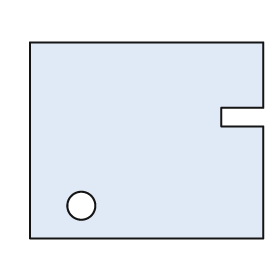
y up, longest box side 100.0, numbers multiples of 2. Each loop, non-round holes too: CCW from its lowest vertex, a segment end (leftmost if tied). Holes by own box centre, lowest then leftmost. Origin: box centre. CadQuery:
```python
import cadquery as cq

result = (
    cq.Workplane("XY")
    .moveTo(-50.0, -42.0)
    .lineTo(50.0, -42.0)
    .lineTo(50.0, 6.0)
    .lineTo(32.0, 6.0)
    .lineTo(32.0, 14.0)
    .lineTo(50.0, 14.0)
    .lineTo(50.0, 42.0)
    .lineTo(-50.0, 42.0)
    .close()
    .moveTo(-28.0, -28.0)
    .circle(6.0)
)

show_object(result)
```